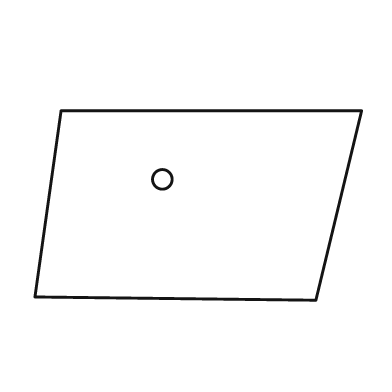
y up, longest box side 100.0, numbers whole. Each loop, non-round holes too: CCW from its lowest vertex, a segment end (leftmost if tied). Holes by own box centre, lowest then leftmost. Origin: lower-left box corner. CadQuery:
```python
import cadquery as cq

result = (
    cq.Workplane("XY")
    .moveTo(86.0, 0.0)
    .lineTo(100.0, 58.0)
    .lineTo(8.0, 58.0)
    .lineTo(0.0, 1.0)
    .close()
    .moveTo(39.0, 37.0)
    .circle(3.0)
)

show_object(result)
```